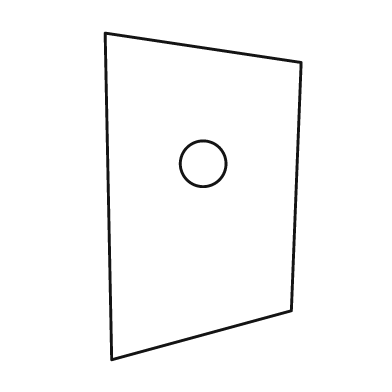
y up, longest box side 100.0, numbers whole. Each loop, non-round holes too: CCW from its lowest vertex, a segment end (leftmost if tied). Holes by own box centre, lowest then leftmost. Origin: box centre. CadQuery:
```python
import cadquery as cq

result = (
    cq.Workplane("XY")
    .moveTo(-28.0, -50.0)
    .lineTo(27.0, -35.0)
    .lineTo(30.0, 41.0)
    .lineTo(-30.0, 50.0)
    .close()
    .moveTo(0.0, 10.0)
    .circle(7.0)
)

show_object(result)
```